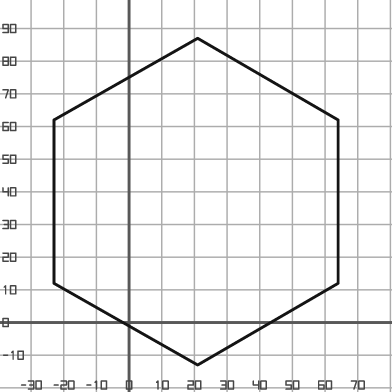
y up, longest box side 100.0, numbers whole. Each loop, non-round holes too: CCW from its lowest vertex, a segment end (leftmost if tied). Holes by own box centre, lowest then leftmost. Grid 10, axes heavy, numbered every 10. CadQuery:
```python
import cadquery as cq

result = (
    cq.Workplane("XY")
    .moveTo(21.0, -13.0)
    .lineTo(64.0, 12.0)
    .lineTo(64.0, 62.0)
    .lineTo(21.0, 87.0)
    .lineTo(-23.0, 62.0)
    .lineTo(-23.0, 12.0)
    .close()
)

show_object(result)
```